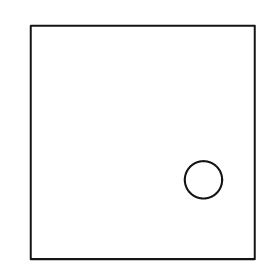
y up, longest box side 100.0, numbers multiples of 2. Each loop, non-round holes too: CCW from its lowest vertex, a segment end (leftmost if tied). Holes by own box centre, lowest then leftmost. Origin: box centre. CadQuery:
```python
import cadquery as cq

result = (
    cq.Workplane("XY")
    .moveTo(-48.0, -50.0)
    .lineTo(48.0, -50.0)
    .lineTo(48.0, 50.0)
    .lineTo(-48.0, 50.0)
    .close()
    .moveTo(26.0, -16.0)
    .circle(8.0)
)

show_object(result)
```